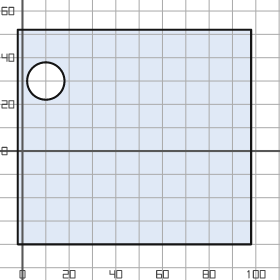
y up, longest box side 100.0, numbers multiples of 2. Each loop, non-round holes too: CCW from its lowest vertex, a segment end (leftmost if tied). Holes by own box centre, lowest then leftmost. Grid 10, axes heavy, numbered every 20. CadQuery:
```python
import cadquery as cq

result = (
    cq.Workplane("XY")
    .moveTo(-2.0, -40.0)
    .lineTo(98.0, -40.0)
    .lineTo(98.0, 52.0)
    .lineTo(-2.0, 52.0)
    .close()
    .moveTo(10.0, 30.0)
    .circle(8.0)
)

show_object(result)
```